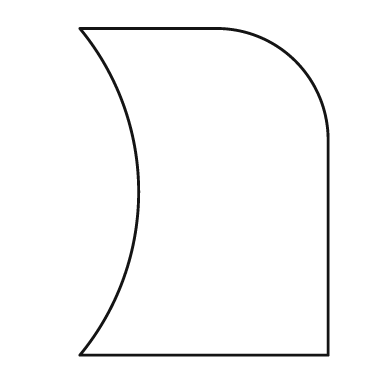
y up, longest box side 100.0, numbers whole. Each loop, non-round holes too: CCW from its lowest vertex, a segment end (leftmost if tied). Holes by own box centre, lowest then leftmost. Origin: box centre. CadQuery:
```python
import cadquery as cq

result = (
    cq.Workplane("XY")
    .moveTo(-38.0, -50.0)
    .lineTo(38.0, -50.0)
    .lineTo(38.0, 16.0)
    .threePointArc((28.0, 40.0), (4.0, 50.0))
    .lineTo(-38.0, 50.0)
    .threePointArc((-20.0, 0.0), (-38.0, -50.0))
    .close()
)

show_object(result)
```